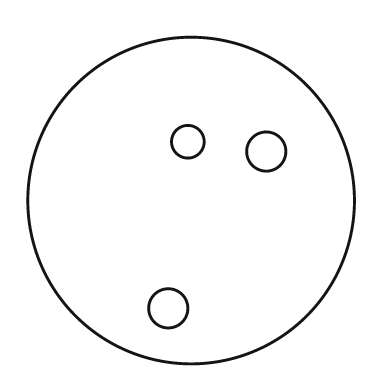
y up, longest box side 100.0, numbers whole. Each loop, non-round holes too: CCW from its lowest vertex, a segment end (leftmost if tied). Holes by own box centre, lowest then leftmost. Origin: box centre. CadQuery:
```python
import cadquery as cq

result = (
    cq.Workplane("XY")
    .moveTo(0.0, 0.0)
    .circle(50.0)
    .moveTo(-7.0, -33.0)
    .circle(6.0)
    .moveTo(23.0, 15.0)
    .circle(6.0)
    .moveTo(-1.0, 18.0)
    .circle(5.0)
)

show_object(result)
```